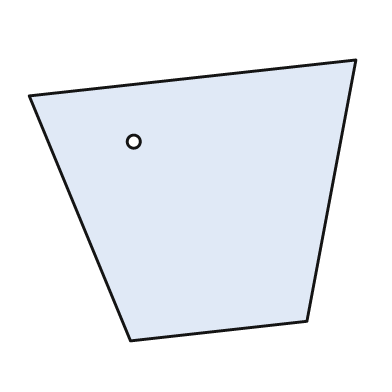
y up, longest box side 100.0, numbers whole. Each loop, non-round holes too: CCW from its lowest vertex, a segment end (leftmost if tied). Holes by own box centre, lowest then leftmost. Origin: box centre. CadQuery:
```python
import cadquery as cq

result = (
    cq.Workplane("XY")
    .moveTo(-19.0, -43.0)
    .lineTo(35.0, -37.0)
    .lineTo(50.0, 43.0)
    .lineTo(-50.0, 32.0)
    .close()
    .moveTo(-18.0, 18.0)
    .circle(2.0)
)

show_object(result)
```